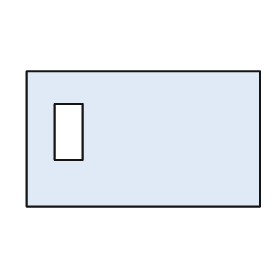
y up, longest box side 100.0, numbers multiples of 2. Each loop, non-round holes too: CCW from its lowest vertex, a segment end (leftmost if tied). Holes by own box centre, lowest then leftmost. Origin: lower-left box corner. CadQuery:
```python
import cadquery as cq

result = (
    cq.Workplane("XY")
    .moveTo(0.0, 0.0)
    .lineTo(100.0, 0.0)
    .lineTo(100.0, 58.0)
    .lineTo(0.0, 58.0)
    .close()
    .moveTo(12.0, 20.0)
    .lineTo(24.0, 20.0)
    .lineTo(24.0, 44.0)
    .lineTo(12.0, 44.0)
    .close()
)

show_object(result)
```